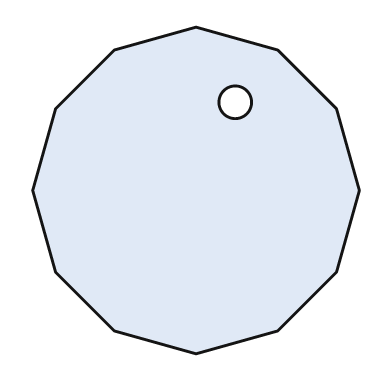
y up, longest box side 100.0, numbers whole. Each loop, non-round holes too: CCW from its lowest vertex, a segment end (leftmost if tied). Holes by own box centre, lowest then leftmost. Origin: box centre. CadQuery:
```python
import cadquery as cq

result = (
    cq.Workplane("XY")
    .moveTo(0.0, -50.0)
    .lineTo(25.0, -43.0)
    .lineTo(43.0, -25.0)
    .lineTo(50.0, 0.0)
    .lineTo(43.0, 25.0)
    .lineTo(25.0, 43.0)
    .lineTo(0.0, 50.0)
    .lineTo(-25.0, 43.0)
    .lineTo(-43.0, 25.0)
    .lineTo(-50.0, 0.0)
    .lineTo(-43.0, -25.0)
    .lineTo(-25.0, -43.0)
    .close()
    .moveTo(12.0, 27.0)
    .circle(5.0)
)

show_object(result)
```